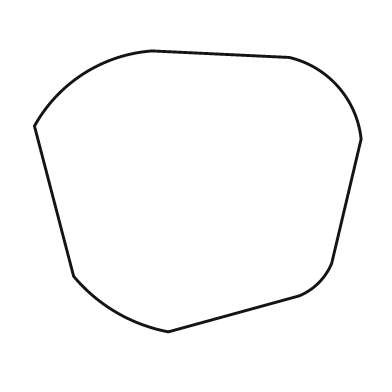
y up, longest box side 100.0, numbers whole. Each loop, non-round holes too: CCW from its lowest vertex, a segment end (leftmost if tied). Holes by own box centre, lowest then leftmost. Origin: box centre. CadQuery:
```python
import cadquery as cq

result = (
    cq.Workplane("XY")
    .moveTo(-9.0, -43.0)
    .lineTo(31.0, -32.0)
    .threePointArc((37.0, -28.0), (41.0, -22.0))
    .lineTo(50.0, 16.0)
    .threePointArc((43.0, 32.0), (28.0, 41.0))
    .lineTo(-14.0, 43.0)
    .threePointArc((-35.0, 36.0), (-50.0, 20.0))
    .lineTo(-38.0, -26.0)
    .threePointArc((-25.0, -37.0), (-9.0, -43.0))
    .close()
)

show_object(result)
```